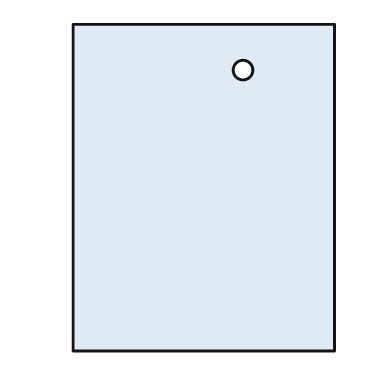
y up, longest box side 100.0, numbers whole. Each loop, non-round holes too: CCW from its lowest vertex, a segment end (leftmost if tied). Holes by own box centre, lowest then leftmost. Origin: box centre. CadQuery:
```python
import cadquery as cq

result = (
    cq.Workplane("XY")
    .moveTo(-40.0, -50.0)
    .lineTo(40.0, -50.0)
    .lineTo(40.0, 50.0)
    .lineTo(-40.0, 50.0)
    .close()
    .moveTo(12.0, 36.0)
    .circle(3.0)
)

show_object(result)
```